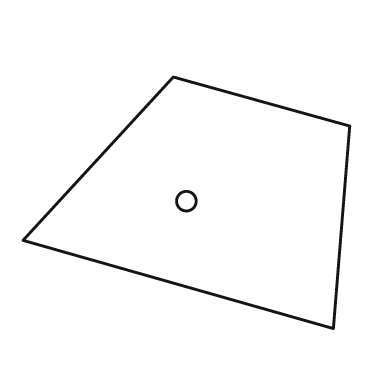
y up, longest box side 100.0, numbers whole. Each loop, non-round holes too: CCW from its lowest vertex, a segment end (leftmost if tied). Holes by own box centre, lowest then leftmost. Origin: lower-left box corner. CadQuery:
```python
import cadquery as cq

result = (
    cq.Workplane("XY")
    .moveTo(95.0, 0.0)
    .lineTo(100.0, 62.0)
    .lineTo(46.0, 77.0)
    .lineTo(0.0, 27.0)
    .close()
    .moveTo(50.0, 39.0)
    .circle(3.0)
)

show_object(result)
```